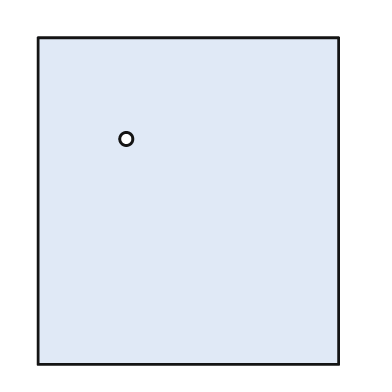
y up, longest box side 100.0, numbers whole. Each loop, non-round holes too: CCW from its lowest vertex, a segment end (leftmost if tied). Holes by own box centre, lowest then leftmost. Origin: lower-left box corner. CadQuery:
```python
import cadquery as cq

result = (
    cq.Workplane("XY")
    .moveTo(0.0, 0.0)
    .lineTo(92.0, 0.0)
    .lineTo(92.0, 100.0)
    .lineTo(0.0, 100.0)
    .close()
    .moveTo(27.0, 69.0)
    .circle(2.0)
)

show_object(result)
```